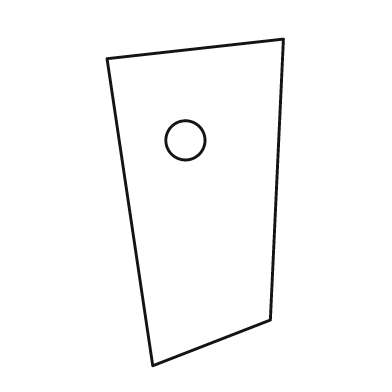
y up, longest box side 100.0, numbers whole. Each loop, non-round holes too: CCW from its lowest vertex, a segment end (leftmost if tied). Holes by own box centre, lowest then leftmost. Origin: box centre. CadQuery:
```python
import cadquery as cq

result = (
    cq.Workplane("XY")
    .moveTo(-13.0, -50.0)
    .lineTo(23.0, -36.0)
    .lineTo(27.0, 50.0)
    .lineTo(-27.0, 44.0)
    .close()
    .moveTo(-3.0, 19.0)
    .circle(6.0)
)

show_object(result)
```